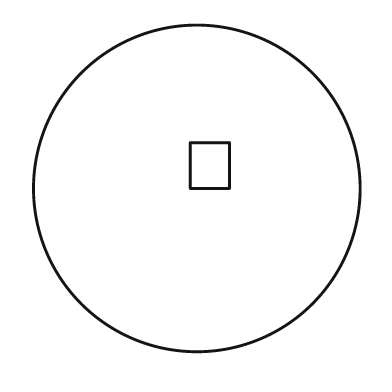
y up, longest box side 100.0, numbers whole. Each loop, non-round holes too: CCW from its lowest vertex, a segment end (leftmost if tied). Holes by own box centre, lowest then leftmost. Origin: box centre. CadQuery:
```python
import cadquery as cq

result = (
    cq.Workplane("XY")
    .moveTo(0.0, 0.0)
    .circle(50.0)
    .moveTo(-2.0, 0.0)
    .lineTo(10.0, 0.0)
    .lineTo(10.0, 14.0)
    .lineTo(-2.0, 14.0)
    .close()
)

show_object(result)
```